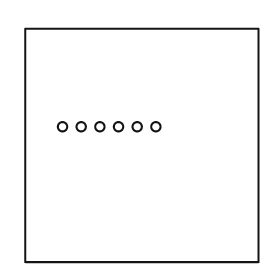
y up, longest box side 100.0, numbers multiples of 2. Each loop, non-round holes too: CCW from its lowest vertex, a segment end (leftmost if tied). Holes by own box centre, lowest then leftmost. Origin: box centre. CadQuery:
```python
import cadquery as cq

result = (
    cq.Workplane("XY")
    .moveTo(-50.0, -50.0)
    .lineTo(50.0, -50.0)
    .lineTo(50.0, 50.0)
    .lineTo(-50.0, 50.0)
    .close()
    .moveTo(-34.0, 8.0)
    .circle(2.0)
    .moveTo(-26.0, 8.0)
    .circle(2.0)
    .moveTo(-18.0, 8.0)
    .circle(2.0)
    .moveTo(-10.0, 8.0)
    .circle(2.0)
    .moveTo(-2.0, 8.0)
    .circle(2.0)
    .moveTo(6.0, 8.0)
    .circle(2.0)
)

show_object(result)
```